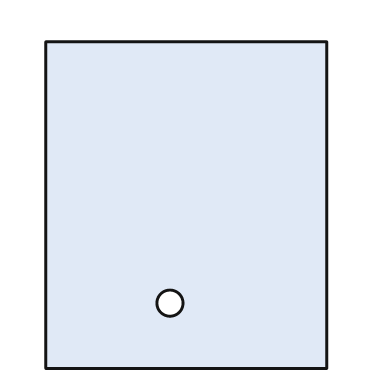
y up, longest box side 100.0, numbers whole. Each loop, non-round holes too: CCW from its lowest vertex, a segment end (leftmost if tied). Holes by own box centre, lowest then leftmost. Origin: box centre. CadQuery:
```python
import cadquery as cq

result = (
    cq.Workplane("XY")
    .moveTo(-43.0, -50.0)
    .lineTo(43.0, -50.0)
    .lineTo(43.0, 50.0)
    .lineTo(-43.0, 50.0)
    .close()
    .moveTo(-5.0, -30.0)
    .circle(4.0)
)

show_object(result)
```